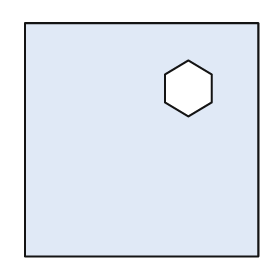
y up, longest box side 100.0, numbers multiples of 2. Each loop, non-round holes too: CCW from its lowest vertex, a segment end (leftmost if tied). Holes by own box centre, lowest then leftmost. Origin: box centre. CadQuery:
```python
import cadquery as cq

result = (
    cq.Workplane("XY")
    .moveTo(-50.0, -50.0)
    .lineTo(50.0, -50.0)
    .lineTo(50.0, 50.0)
    .lineTo(-50.0, 50.0)
    .close()
    .moveTo(20.0, 10.0)
    .lineTo(30.0, 16.0)
    .lineTo(30.0, 28.0)
    .lineTo(20.0, 34.0)
    .lineTo(10.0, 28.0)
    .lineTo(10.0, 16.0)
    .close()
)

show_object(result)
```